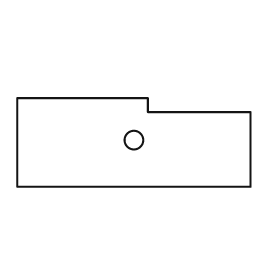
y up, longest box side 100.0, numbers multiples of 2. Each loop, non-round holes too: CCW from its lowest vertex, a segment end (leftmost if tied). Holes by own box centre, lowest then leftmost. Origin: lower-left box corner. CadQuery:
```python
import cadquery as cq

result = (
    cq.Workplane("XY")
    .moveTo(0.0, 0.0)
    .lineTo(100.0, 0.0)
    .lineTo(100.0, 32.0)
    .lineTo(56.0, 32.0)
    .lineTo(56.0, 38.0)
    .lineTo(0.0, 38.0)
    .close()
    .moveTo(50.0, 20.0)
    .circle(4.0)
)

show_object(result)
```